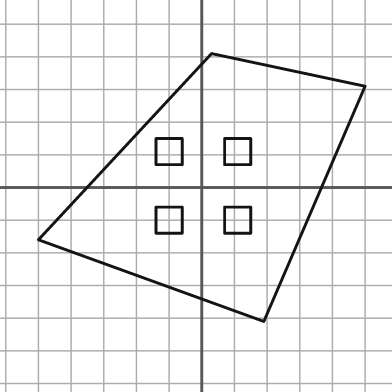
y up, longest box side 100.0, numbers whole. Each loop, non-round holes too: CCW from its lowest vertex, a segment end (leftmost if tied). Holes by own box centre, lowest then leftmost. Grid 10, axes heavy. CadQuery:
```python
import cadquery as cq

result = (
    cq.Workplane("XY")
    .moveTo(19.0, -41.0)
    .lineTo(50.0, 31.0)
    .lineTo(3.0, 41.0)
    .lineTo(-50.0, -16.0)
    .close()
    .moveTo(-14.0, -14.0)
    .lineTo(-6.0, -14.0)
    .lineTo(-6.0, -6.0)
    .lineTo(-14.0, -6.0)
    .close()
    .moveTo(7.0, -14.0)
    .lineTo(15.0, -14.0)
    .lineTo(15.0, -6.0)
    .lineTo(7.0, -6.0)
    .close()
    .moveTo(-14.0, 7.0)
    .lineTo(-6.0, 7.0)
    .lineTo(-6.0, 15.0)
    .lineTo(-14.0, 15.0)
    .close()
    .moveTo(7.0, 7.0)
    .lineTo(15.0, 7.0)
    .lineTo(15.0, 15.0)
    .lineTo(7.0, 15.0)
    .close()
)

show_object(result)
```